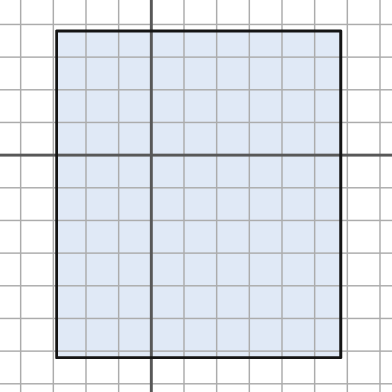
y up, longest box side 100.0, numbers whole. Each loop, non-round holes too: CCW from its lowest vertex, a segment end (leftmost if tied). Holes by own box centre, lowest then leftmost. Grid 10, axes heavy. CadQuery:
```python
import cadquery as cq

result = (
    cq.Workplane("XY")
    .moveTo(-29.0, -62.0)
    .lineTo(58.0, -62.0)
    .lineTo(58.0, 38.0)
    .lineTo(-29.0, 38.0)
    .close()
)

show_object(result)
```